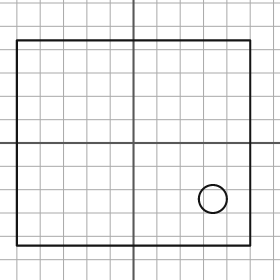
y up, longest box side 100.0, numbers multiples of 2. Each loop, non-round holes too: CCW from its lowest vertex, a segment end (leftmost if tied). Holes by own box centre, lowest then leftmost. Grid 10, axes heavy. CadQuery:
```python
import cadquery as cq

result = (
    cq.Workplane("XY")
    .moveTo(-50.0, -44.0)
    .lineTo(50.0, -44.0)
    .lineTo(50.0, 44.0)
    .lineTo(-50.0, 44.0)
    .close()
    .moveTo(34.0, -24.0)
    .circle(6.0)
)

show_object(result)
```